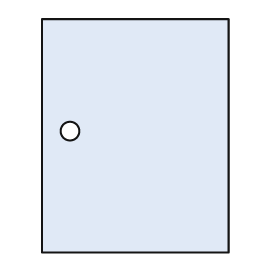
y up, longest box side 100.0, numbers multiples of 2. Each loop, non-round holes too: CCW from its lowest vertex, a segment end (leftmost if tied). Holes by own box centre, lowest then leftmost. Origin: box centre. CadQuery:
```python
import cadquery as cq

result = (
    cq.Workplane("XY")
    .moveTo(-40.0, -50.0)
    .lineTo(40.0, -50.0)
    .lineTo(40.0, 50.0)
    .lineTo(-40.0, 50.0)
    .close()
    .moveTo(-28.0, 2.0)
    .circle(4.0)
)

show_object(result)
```